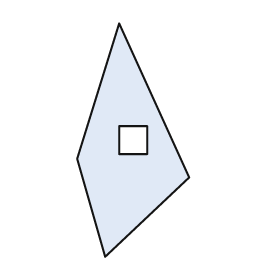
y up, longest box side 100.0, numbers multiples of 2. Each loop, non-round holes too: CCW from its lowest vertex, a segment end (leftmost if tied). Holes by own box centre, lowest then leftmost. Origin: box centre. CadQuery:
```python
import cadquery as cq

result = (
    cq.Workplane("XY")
    .moveTo(-12.0, -50.0)
    .lineTo(24.0, -16.0)
    .lineTo(-6.0, 50.0)
    .lineTo(-24.0, -8.0)
    .close()
    .moveTo(-6.0, -6.0)
    .lineTo(6.0, -6.0)
    .lineTo(6.0, 6.0)
    .lineTo(-6.0, 6.0)
    .close()
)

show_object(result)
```